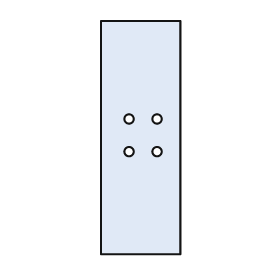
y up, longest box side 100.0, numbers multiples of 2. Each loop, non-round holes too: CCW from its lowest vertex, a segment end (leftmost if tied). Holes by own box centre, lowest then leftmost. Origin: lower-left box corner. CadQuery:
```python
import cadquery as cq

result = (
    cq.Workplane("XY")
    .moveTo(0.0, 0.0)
    .lineTo(34.0, 0.0)
    .lineTo(34.0, 100.0)
    .lineTo(0.0, 100.0)
    .close()
    .moveTo(12.0, 44.0)
    .circle(2.0)
    .moveTo(24.0, 44.0)
    .circle(2.0)
    .moveTo(12.0, 58.0)
    .circle(2.0)
    .moveTo(24.0, 58.0)
    .circle(2.0)
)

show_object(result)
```